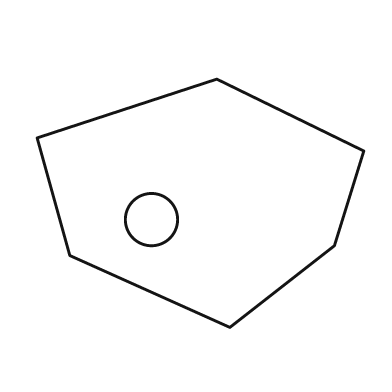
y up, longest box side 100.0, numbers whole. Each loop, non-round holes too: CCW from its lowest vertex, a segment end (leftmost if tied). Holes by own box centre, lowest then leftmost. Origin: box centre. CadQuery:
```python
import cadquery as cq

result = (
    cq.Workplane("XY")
    .moveTo(9.0, -38.0)
    .lineTo(41.0, -13.0)
    .lineTo(50.0, 16.0)
    .lineTo(5.0, 38.0)
    .lineTo(-50.0, 20.0)
    .lineTo(-40.0, -16.0)
    .close()
    .moveTo(-15.0, -5.0)
    .circle(8.0)
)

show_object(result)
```